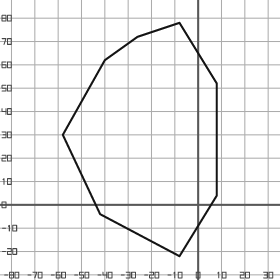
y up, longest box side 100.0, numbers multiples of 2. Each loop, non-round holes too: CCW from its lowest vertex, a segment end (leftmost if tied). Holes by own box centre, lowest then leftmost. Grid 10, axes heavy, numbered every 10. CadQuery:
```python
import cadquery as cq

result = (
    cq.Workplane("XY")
    .moveTo(-8.0, -22.0)
    .lineTo(8.0, 4.0)
    .lineTo(8.0, 52.0)
    .lineTo(-8.0, 78.0)
    .lineTo(-26.0, 72.0)
    .lineTo(-40.0, 62.0)
    .lineTo(-58.0, 30.0)
    .lineTo(-42.0, -4.0)
    .close()
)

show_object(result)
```